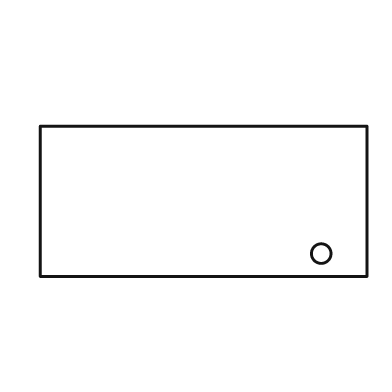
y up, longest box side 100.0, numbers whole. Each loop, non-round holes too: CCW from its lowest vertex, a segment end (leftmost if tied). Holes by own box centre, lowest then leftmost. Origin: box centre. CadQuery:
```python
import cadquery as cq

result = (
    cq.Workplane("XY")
    .moveTo(-50.0, -23.0)
    .lineTo(50.0, -23.0)
    .lineTo(50.0, 23.0)
    .lineTo(-50.0, 23.0)
    .close()
    .moveTo(36.0, -16.0)
    .circle(3.0)
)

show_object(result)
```